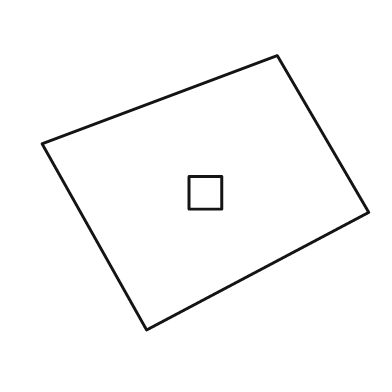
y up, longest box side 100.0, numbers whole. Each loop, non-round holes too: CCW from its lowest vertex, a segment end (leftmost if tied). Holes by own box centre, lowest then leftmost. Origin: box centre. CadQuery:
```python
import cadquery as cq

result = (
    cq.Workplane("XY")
    .moveTo(-18.0, -42.0)
    .lineTo(50.0, -6.0)
    .lineTo(22.0, 42.0)
    .lineTo(-50.0, 15.0)
    .close()
    .moveTo(-5.0, -5.0)
    .lineTo(5.0, -5.0)
    .lineTo(5.0, 5.0)
    .lineTo(-5.0, 5.0)
    .close()
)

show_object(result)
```